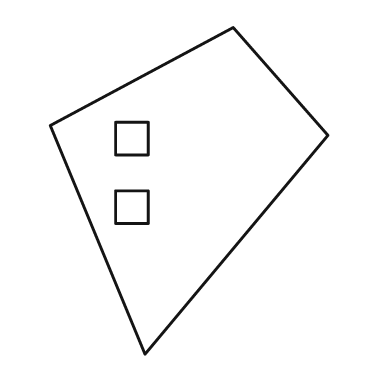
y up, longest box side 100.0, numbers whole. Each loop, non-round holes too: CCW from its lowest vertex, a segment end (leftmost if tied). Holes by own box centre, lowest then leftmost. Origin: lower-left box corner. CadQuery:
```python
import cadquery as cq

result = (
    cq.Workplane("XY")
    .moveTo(29.0, 0.0)
    .lineTo(85.0, 67.0)
    .lineTo(56.0, 100.0)
    .lineTo(0.0, 70.0)
    .close()
    .moveTo(20.0, 40.0)
    .lineTo(30.0, 40.0)
    .lineTo(30.0, 50.0)
    .lineTo(20.0, 50.0)
    .close()
    .moveTo(20.0, 61.0)
    .lineTo(30.0, 61.0)
    .lineTo(30.0, 71.0)
    .lineTo(20.0, 71.0)
    .close()
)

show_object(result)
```